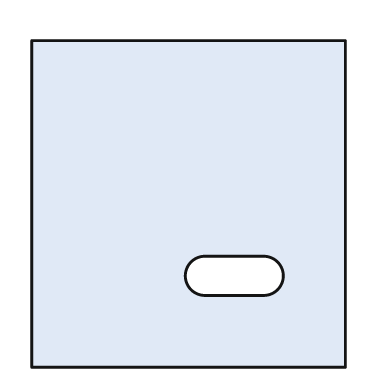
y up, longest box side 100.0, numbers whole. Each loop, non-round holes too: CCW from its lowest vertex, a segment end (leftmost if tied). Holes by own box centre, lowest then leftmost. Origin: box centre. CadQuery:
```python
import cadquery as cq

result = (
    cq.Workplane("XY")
    .moveTo(-48.0, -50.0)
    .lineTo(48.0, -50.0)
    .lineTo(48.0, 50.0)
    .lineTo(-48.0, 50.0)
    .close()
    .moveTo(5.0, -28.0)
    .lineTo(23.0, -28.0)
    .threePointArc((29.0, -22.0), (23.0, -16.0))
    .lineTo(5.0, -16.0)
    .threePointArc((-1.0, -22.0), (5.0, -28.0))
    .close()
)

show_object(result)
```